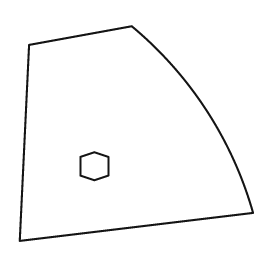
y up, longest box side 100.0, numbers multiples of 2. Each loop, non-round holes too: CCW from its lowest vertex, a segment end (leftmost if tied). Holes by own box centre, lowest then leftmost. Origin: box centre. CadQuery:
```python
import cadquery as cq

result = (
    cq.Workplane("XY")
    .moveTo(-50.0, -46.0)
    .lineTo(50.0, -34.0)
    .threePointArc((30.0, 10.0), (-2.0, 46.0))
    .lineTo(-46.0, 38.0)
    .close()
    .moveTo(-18.0, -20.0)
    .lineTo(-12.0, -18.0)
    .lineTo(-12.0, -10.0)
    .lineTo(-18.0, -8.0)
    .lineTo(-24.0, -10.0)
    .lineTo(-24.0, -18.0)
    .close()
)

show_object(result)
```